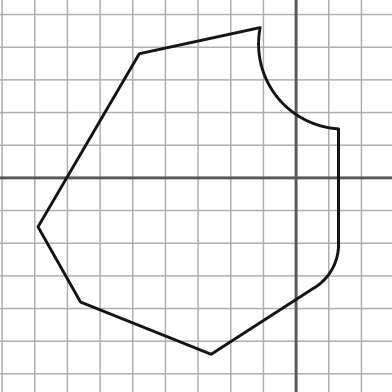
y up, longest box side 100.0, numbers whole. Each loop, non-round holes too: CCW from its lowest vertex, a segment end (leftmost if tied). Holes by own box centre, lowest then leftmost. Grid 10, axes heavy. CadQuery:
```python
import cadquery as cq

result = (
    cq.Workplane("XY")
    .moveTo(-26.0, -54.0)
    .lineTo(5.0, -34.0)
    .threePointArc((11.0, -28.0), (13.0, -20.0))
    .lineTo(13.0, 15.0)
    .threePointArc((-6.0, 25.0), (-11.0, 46.0))
    .lineTo(-48.0, 38.0)
    .lineTo(-79.0, -15.0)
    .lineTo(-66.0, -38.0)
    .close()
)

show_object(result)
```